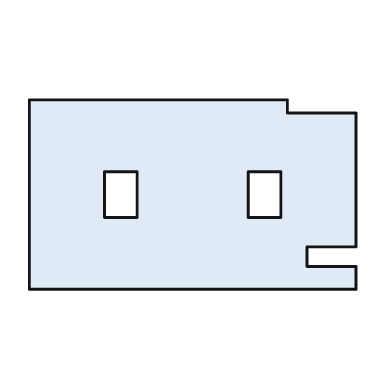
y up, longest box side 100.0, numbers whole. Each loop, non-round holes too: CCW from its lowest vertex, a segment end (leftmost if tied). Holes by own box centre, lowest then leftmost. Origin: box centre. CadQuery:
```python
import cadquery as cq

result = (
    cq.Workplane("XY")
    .moveTo(-50.0, -29.0)
    .lineTo(50.0, -29.0)
    .lineTo(50.0, -22.0)
    .lineTo(35.0, -22.0)
    .lineTo(35.0, -16.0)
    .lineTo(50.0, -16.0)
    .lineTo(50.0, 25.0)
    .lineTo(29.0, 25.0)
    .lineTo(29.0, 29.0)
    .lineTo(-50.0, 29.0)
    .close()
    .moveTo(-27.0, -7.0)
    .lineTo(-17.0, -7.0)
    .lineTo(-17.0, 7.0)
    .lineTo(-27.0, 7.0)
    .close()
    .moveTo(17.0, -7.0)
    .lineTo(27.0, -7.0)
    .lineTo(27.0, 7.0)
    .lineTo(17.0, 7.0)
    .close()
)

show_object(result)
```